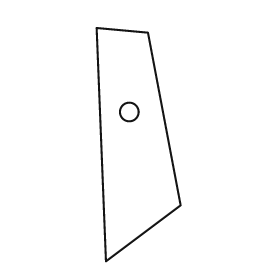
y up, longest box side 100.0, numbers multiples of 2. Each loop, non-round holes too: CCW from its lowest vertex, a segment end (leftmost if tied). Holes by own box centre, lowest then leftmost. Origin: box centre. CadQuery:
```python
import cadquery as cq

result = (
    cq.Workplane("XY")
    .moveTo(-14.0, -50.0)
    .lineTo(18.0, -26.0)
    .lineTo(4.0, 48.0)
    .lineTo(-18.0, 50.0)
    .close()
    .moveTo(-4.0, 14.0)
    .circle(4.0)
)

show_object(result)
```